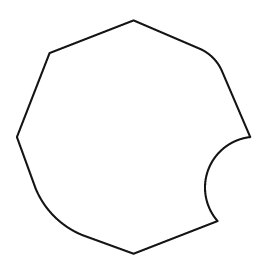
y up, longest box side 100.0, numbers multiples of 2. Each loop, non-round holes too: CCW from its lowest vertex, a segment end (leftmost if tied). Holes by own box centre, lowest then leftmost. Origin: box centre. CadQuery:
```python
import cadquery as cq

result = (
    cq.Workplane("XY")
    .moveTo(0.0, -50.0)
    .lineTo(36.0, -36.0)
    .threePointArc((32.0, -14.0), (50.0, 0.0))
    .lineTo(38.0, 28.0)
    .threePointArc((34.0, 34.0), (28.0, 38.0))
    .lineTo(0.0, 50.0)
    .lineTo(-36.0, 36.0)
    .lineTo(-50.0, 0.0)
    .lineTo(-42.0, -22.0)
    .threePointArc((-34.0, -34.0), (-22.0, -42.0))
    .close()
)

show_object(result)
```